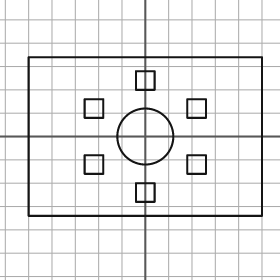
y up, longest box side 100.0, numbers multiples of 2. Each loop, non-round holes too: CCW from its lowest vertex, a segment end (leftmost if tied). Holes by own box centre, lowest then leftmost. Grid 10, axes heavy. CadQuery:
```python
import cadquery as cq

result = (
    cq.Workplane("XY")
    .moveTo(-50.0, -34.0)
    .lineTo(50.0, -34.0)
    .lineTo(50.0, 34.0)
    .lineTo(-50.0, 34.0)
    .close()
    .moveTo(-4.0, -28.0)
    .lineTo(4.0, -28.0)
    .lineTo(4.0, -20.0)
    .lineTo(-4.0, -20.0)
    .close()
    .moveTo(-26.0, -16.0)
    .lineTo(-18.0, -16.0)
    .lineTo(-18.0, -8.0)
    .lineTo(-26.0, -8.0)
    .close()
    .moveTo(18.0, -16.0)
    .lineTo(26.0, -16.0)
    .lineTo(26.0, -8.0)
    .lineTo(18.0, -8.0)
    .close()
    .moveTo(0.0, 0.0)
    .circle(12.0)
    .moveTo(-26.0, 8.0)
    .lineTo(-18.0, 8.0)
    .lineTo(-18.0, 16.0)
    .lineTo(-26.0, 16.0)
    .close()
    .moveTo(18.0, 8.0)
    .lineTo(26.0, 8.0)
    .lineTo(26.0, 16.0)
    .lineTo(18.0, 16.0)
    .close()
    .moveTo(-4.0, 20.0)
    .lineTo(4.0, 20.0)
    .lineTo(4.0, 28.0)
    .lineTo(-4.0, 28.0)
    .close()
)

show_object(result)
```